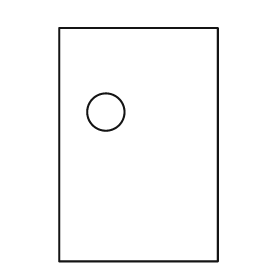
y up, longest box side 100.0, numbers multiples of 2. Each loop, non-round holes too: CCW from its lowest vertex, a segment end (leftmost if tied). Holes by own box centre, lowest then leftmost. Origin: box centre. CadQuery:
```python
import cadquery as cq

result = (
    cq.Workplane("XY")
    .moveTo(-34.0, -50.0)
    .lineTo(34.0, -50.0)
    .lineTo(34.0, 50.0)
    .lineTo(-34.0, 50.0)
    .close()
    .moveTo(-14.0, 14.0)
    .circle(8.0)
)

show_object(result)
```